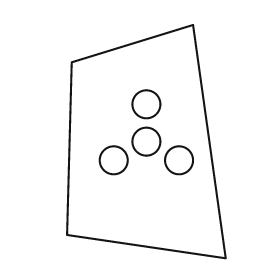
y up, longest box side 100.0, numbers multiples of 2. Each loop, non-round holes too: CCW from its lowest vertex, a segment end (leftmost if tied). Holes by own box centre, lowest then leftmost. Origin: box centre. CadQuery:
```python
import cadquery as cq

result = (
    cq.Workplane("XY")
    .moveTo(34.0, -50.0)
    .lineTo(20.0, 50.0)
    .lineTo(-32.0, 34.0)
    .lineTo(-34.0, -40.0)
    .close()
    .moveTo(-14.0, -8.0)
    .circle(6.0)
    .moveTo(14.0, -8.0)
    .circle(6.0)
    .moveTo(0.0, 0.0)
    .circle(6.0)
    .moveTo(0.0, 16.0)
    .circle(6.0)
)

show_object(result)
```